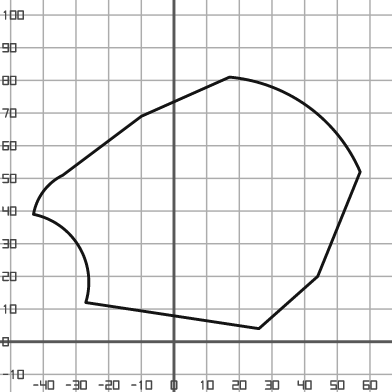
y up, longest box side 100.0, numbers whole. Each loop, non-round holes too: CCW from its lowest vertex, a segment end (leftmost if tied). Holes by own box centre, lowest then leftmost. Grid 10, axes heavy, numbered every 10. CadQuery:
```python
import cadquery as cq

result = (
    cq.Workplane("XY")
    .moveTo(26.0, 4.0)
    .lineTo(44.0, 20.0)
    .lineTo(57.0, 52.0)
    .threePointArc((41.0, 72.0), (17.0, 81.0))
    .lineTo(-10.0, 69.0)
    .lineTo(-34.0, 51.0)
    .threePointArc((-40.0, 46.0), (-43.0, 39.0))
    .threePointArc((-29.0, 29.0), (-27.0, 12.0))
    .close()
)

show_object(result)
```